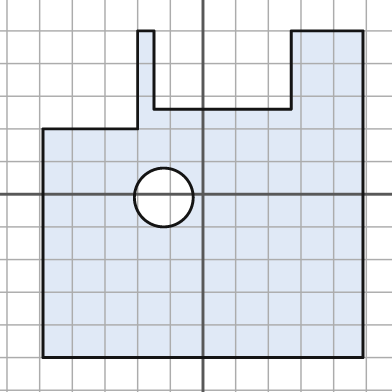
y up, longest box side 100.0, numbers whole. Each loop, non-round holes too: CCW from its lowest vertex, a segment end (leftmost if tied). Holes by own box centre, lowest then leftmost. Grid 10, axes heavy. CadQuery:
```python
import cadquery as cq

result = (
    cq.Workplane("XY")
    .moveTo(-49.0, -50.0)
    .lineTo(49.0, -50.0)
    .lineTo(49.0, 50.0)
    .lineTo(27.0, 50.0)
    .lineTo(27.0, 26.0)
    .lineTo(-15.0, 26.0)
    .lineTo(-15.0, 50.0)
    .lineTo(-20.0, 50.0)
    .lineTo(-20.0, 20.0)
    .lineTo(-49.0, 20.0)
    .close()
    .moveTo(-12.0, -1.0)
    .circle(9.0)
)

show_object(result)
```